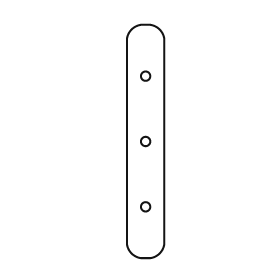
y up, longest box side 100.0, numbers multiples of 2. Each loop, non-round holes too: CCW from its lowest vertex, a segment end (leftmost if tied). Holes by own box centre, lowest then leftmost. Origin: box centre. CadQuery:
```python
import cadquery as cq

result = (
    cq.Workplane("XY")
    .moveTo(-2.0, -50.0)
    .lineTo(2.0, -50.0)
    .threePointArc((6.0, -48.0), (8.0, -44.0))
    .lineTo(8.0, 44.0)
    .threePointArc((6.0, 48.0), (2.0, 50.0))
    .lineTo(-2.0, 50.0)
    .threePointArc((-6.0, 48.0), (-8.0, 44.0))
    .lineTo(-8.0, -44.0)
    .threePointArc((-6.0, -48.0), (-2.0, -50.0))
    .close()
    .moveTo(0.0, -28.0)
    .circle(2.0)
    .moveTo(0.0, 0.0)
    .circle(2.0)
    .moveTo(0.0, 28.0)
    .circle(2.0)
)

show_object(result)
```